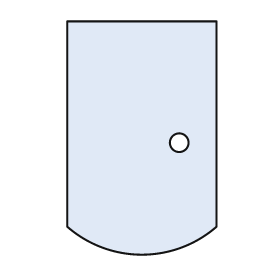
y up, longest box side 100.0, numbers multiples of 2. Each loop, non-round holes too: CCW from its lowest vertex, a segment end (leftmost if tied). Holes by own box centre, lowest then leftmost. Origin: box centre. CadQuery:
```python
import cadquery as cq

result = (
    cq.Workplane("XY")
    .moveTo(-32.0, -38.0)
    .threePointArc((0.0, -50.0), (32.0, -38.0))
    .lineTo(32.0, 50.0)
    .lineTo(-32.0, 50.0)
    .close()
    .moveTo(16.0, -2.0)
    .circle(4.0)
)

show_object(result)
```